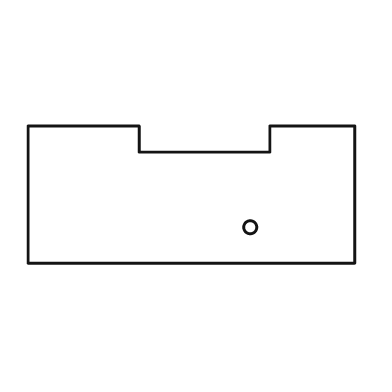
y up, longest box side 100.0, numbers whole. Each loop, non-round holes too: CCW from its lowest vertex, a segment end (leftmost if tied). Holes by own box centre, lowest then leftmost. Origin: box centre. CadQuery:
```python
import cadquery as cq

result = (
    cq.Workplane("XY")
    .moveTo(-50.0, -21.0)
    .lineTo(50.0, -21.0)
    .lineTo(50.0, 21.0)
    .lineTo(24.0, 21.0)
    .lineTo(24.0, 13.0)
    .lineTo(-16.0, 13.0)
    .lineTo(-16.0, 21.0)
    .lineTo(-50.0, 21.0)
    .close()
    .moveTo(18.0, -10.0)
    .circle(2.0)
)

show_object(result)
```